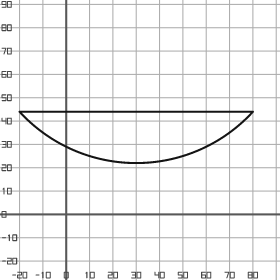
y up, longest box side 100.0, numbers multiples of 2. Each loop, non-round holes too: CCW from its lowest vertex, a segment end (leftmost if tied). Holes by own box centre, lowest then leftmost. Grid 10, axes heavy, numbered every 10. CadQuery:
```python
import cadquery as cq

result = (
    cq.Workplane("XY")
    .moveTo(-20.0, 44.0)
    .threePointArc((30.0, 22.0), (80.0, 44.0))
    .close()
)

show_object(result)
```